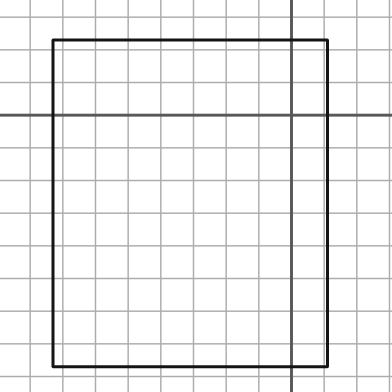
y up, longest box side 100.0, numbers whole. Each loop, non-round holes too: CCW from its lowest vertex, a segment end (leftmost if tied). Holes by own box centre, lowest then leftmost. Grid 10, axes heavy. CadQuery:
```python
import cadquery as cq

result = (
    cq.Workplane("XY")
    .moveTo(-73.0, -77.0)
    .lineTo(11.0, -77.0)
    .lineTo(11.0, 23.0)
    .lineTo(-73.0, 23.0)
    .close()
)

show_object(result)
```